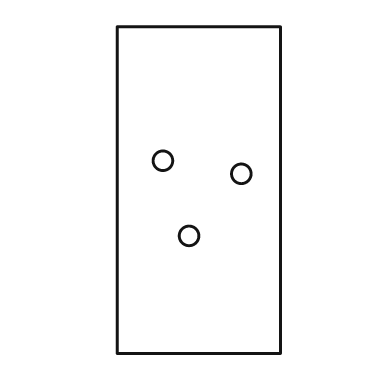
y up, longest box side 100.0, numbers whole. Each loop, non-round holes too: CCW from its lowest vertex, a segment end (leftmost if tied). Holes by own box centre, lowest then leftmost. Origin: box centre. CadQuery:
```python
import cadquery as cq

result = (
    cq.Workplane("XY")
    .moveTo(-25.0, -50.0)
    .lineTo(25.0, -50.0)
    .lineTo(25.0, 50.0)
    .lineTo(-25.0, 50.0)
    .close()
    .moveTo(-3.0, -14.0)
    .circle(3.0)
    .moveTo(13.0, 5.0)
    .circle(3.0)
    .moveTo(-11.0, 9.0)
    .circle(3.0)
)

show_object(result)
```